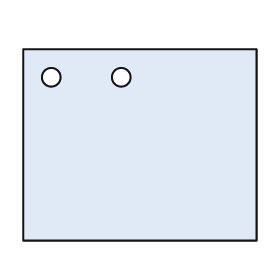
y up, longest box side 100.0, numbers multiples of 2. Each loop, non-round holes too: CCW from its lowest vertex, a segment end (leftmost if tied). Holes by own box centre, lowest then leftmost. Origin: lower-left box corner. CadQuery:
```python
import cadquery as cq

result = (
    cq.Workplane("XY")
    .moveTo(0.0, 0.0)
    .lineTo(100.0, 0.0)
    .lineTo(100.0, 82.0)
    .lineTo(0.0, 82.0)
    .close()
    .moveTo(12.0, 70.0)
    .circle(4.0)
    .moveTo(42.0, 70.0)
    .circle(4.0)
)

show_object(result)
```